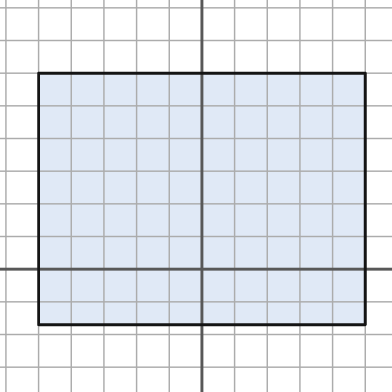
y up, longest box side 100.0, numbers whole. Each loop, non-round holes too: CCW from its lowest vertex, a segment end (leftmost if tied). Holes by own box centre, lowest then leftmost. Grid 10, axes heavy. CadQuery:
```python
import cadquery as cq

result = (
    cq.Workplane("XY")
    .moveTo(-50.0, -17.0)
    .lineTo(50.0, -17.0)
    .lineTo(50.0, 60.0)
    .lineTo(-50.0, 60.0)
    .close()
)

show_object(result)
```